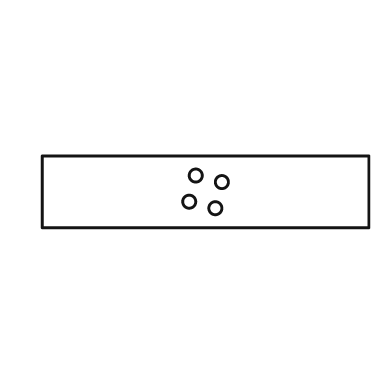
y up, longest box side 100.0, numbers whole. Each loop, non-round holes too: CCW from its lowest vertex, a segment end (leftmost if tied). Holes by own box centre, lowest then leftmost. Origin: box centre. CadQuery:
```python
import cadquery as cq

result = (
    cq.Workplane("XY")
    .moveTo(-50.0, -11.0)
    .lineTo(50.0, -11.0)
    .lineTo(50.0, 11.0)
    .lineTo(-50.0, 11.0)
    .close()
    .moveTo(3.0, -5.0)
    .circle(2.0)
    .moveTo(-5.0, -3.0)
    .circle(2.0)
    .moveTo(5.0, 3.0)
    .circle(2.0)
    .moveTo(-3.0, 5.0)
    .circle(2.0)
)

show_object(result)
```